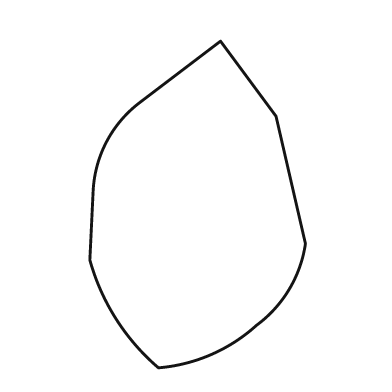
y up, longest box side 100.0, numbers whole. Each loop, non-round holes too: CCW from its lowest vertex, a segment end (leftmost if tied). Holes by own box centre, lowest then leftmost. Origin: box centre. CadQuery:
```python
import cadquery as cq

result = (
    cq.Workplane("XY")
    .moveTo(-12.0, -50.0)
    .threePointArc((4.0, -46.0), (18.0, -37.0))
    .threePointArc((28.0, -26.0), (33.0, -12.0))
    .lineTo(24.0, 27.0)
    .lineTo(7.0, 50.0)
    .lineTo(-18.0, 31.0)
    .threePointArc((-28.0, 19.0), (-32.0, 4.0))
    .lineTo(-33.0, -17.0)
    .threePointArc((-25.0, -35.0), (-12.0, -50.0))
    .close()
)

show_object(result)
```